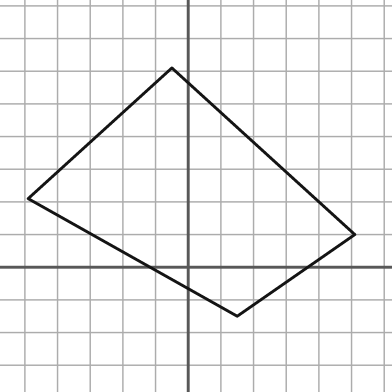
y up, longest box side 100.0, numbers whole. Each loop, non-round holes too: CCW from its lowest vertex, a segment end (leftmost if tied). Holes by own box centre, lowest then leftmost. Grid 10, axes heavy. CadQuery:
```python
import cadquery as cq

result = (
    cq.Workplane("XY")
    .moveTo(15.0, -15.0)
    .lineTo(51.0, 10.0)
    .lineTo(-5.0, 61.0)
    .lineTo(-49.0, 21.0)
    .close()
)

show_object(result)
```